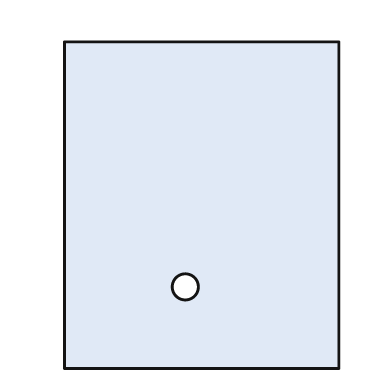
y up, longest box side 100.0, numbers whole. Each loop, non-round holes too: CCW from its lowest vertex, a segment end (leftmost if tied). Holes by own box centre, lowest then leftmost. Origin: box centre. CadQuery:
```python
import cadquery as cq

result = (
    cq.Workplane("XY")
    .moveTo(-42.0, -50.0)
    .lineTo(42.0, -50.0)
    .lineTo(42.0, 50.0)
    .lineTo(-42.0, 50.0)
    .close()
    .moveTo(-5.0, -25.0)
    .circle(4.0)
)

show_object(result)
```